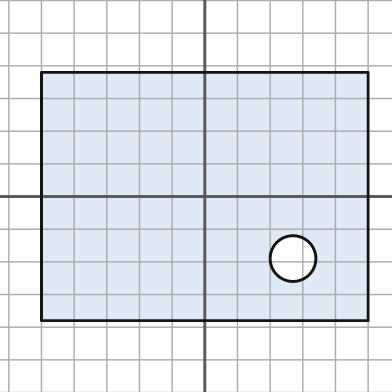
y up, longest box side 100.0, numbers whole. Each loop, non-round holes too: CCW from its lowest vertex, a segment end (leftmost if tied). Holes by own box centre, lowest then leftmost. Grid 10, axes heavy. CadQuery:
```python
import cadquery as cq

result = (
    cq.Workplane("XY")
    .moveTo(-50.0, -38.0)
    .lineTo(50.0, -38.0)
    .lineTo(50.0, 38.0)
    .lineTo(-50.0, 38.0)
    .close()
    .moveTo(27.0, -19.0)
    .circle(7.0)
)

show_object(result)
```